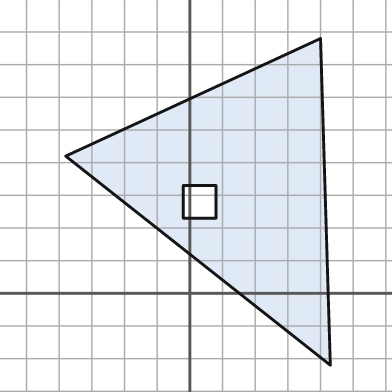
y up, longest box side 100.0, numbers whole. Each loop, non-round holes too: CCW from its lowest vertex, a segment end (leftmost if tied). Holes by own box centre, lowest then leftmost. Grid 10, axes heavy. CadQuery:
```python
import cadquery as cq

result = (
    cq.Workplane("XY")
    .moveTo(43.0, -22.0)
    .lineTo(40.0, 78.0)
    .lineTo(-38.0, 42.0)
    .close()
    .moveTo(-2.0, 23.0)
    .lineTo(8.0, 23.0)
    .lineTo(8.0, 33.0)
    .lineTo(-2.0, 33.0)
    .close()
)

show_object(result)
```